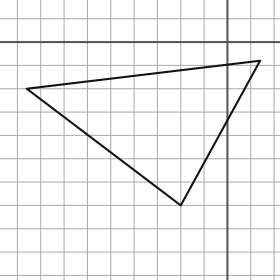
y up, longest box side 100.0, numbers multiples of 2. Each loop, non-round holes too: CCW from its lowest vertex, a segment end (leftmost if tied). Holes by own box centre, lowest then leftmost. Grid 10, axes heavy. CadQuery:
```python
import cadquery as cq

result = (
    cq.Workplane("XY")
    .moveTo(-20.0, -70.0)
    .lineTo(14.0, -8.0)
    .lineTo(-86.0, -20.0)
    .close()
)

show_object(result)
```